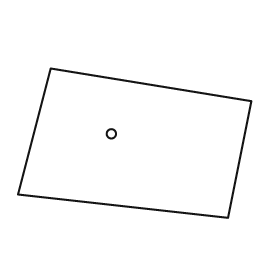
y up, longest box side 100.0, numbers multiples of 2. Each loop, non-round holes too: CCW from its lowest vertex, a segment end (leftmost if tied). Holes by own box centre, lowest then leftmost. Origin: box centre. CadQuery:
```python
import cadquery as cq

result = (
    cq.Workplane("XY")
    .moveTo(40.0, -32.0)
    .lineTo(50.0, 18.0)
    .lineTo(-36.0, 32.0)
    .lineTo(-50.0, -22.0)
    .close()
    .moveTo(-10.0, 4.0)
    .circle(2.0)
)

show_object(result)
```